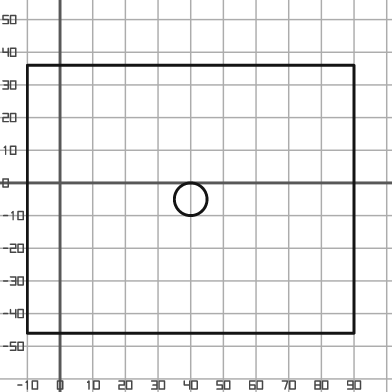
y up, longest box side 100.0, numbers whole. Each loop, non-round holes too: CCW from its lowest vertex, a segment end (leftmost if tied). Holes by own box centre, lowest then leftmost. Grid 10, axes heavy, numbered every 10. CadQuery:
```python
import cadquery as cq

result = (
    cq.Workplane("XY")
    .moveTo(-10.0, -46.0)
    .lineTo(90.0, -46.0)
    .lineTo(90.0, 36.0)
    .lineTo(-10.0, 36.0)
    .close()
    .moveTo(40.0, -5.0)
    .circle(5.0)
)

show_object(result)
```